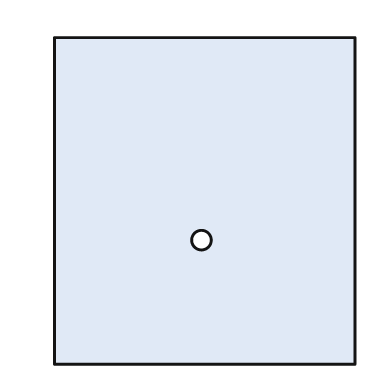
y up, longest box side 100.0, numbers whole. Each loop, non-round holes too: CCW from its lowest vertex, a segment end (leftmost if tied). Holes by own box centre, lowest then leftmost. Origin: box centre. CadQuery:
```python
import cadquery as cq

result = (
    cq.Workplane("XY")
    .moveTo(-46.0, -50.0)
    .lineTo(46.0, -50.0)
    .lineTo(46.0, 50.0)
    .lineTo(-46.0, 50.0)
    .close()
    .moveTo(-1.0, -12.0)
    .circle(3.0)
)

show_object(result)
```